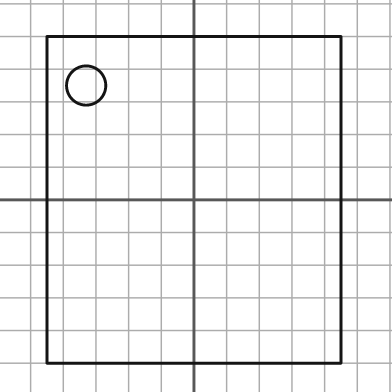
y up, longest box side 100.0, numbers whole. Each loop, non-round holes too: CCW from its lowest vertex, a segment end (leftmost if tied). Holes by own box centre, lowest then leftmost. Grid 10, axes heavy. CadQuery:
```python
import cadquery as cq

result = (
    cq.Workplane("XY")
    .moveTo(-45.0, -50.0)
    .lineTo(45.0, -50.0)
    .lineTo(45.0, 50.0)
    .lineTo(-45.0, 50.0)
    .close()
    .moveTo(-33.0, 35.0)
    .circle(6.0)
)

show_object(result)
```